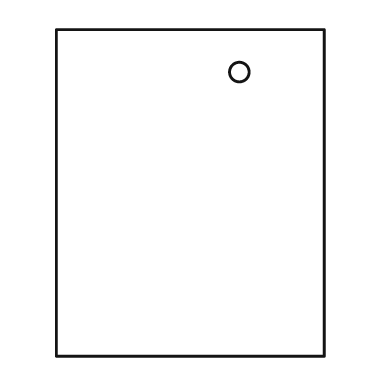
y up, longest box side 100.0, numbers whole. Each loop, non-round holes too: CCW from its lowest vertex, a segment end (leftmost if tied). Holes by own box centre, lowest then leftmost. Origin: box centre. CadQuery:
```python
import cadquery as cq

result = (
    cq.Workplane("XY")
    .moveTo(-41.0, -50.0)
    .lineTo(41.0, -50.0)
    .lineTo(41.0, 50.0)
    .lineTo(-41.0, 50.0)
    .close()
    .moveTo(15.0, 37.0)
    .circle(3.0)
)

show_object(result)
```